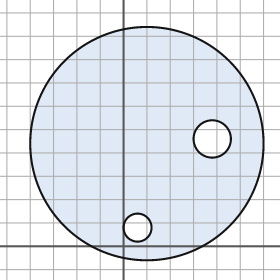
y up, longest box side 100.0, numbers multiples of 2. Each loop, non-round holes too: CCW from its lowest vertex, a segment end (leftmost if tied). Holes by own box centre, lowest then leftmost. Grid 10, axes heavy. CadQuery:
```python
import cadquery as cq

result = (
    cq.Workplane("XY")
    .moveTo(10.0, 44.0)
    .circle(50.0)
    .moveTo(6.0, 8.0)
    .circle(6.0)
    .moveTo(38.0, 46.0)
    .circle(8.0)
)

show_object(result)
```